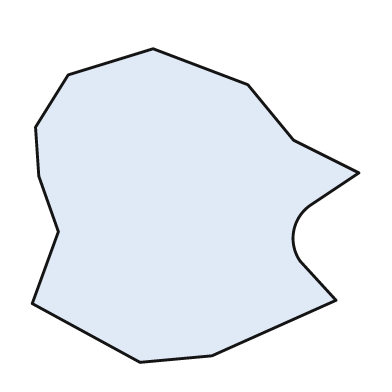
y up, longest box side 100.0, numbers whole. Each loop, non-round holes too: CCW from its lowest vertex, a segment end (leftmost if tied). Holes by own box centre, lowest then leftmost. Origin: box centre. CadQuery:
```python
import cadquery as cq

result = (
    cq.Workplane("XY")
    .moveTo(-17.0, -48.0)
    .lineTo(5.0, -46.0)
    .lineTo(43.0, -29.0)
    .lineTo(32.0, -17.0)
    .threePointArc((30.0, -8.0), (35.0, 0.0))
    .lineTo(50.0, 10.0)
    .lineTo(30.0, 20.0)
    .lineTo(16.0, 37.0)
    .lineTo(-13.0, 48.0)
    .lineTo(-39.0, 40.0)
    .lineTo(-49.0, 24.0)
    .lineTo(-48.0, 9.0)
    .lineTo(-42.0, -8.0)
    .lineTo(-50.0, -30.0)
    .close()
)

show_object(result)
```